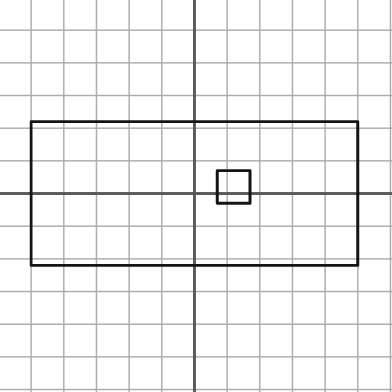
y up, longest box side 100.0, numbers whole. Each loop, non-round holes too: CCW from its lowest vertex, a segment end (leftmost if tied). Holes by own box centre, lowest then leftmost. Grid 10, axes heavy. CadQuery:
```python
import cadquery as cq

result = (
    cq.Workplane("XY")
    .moveTo(-50.0, -22.0)
    .lineTo(50.0, -22.0)
    .lineTo(50.0, 22.0)
    .lineTo(-50.0, 22.0)
    .close()
    .moveTo(7.0, -3.0)
    .lineTo(17.0, -3.0)
    .lineTo(17.0, 7.0)
    .lineTo(7.0, 7.0)
    .close()
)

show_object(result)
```